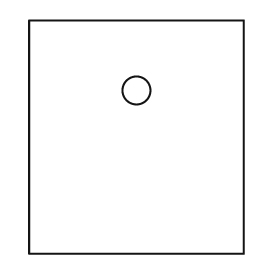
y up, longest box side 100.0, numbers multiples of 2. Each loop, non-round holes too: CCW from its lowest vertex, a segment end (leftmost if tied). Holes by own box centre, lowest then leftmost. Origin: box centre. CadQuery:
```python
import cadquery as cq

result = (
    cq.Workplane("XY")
    .moveTo(-46.0, -50.0)
    .lineTo(46.0, -50.0)
    .lineTo(46.0, 50.0)
    .lineTo(-46.0, 50.0)
    .close()
    .moveTo(0.0, 20.0)
    .circle(6.0)
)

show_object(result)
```